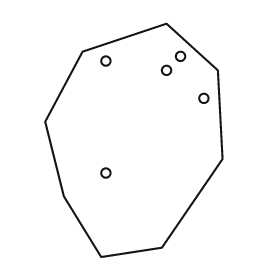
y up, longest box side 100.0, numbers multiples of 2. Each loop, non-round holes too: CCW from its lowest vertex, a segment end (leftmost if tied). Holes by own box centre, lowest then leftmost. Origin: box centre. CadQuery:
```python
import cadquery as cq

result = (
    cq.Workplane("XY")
    .moveTo(-14.0, -50.0)
    .lineTo(12.0, -46.0)
    .lineTo(38.0, -8.0)
    .lineTo(36.0, 30.0)
    .lineTo(14.0, 50.0)
    .lineTo(-22.0, 38.0)
    .lineTo(-38.0, 8.0)
    .lineTo(-30.0, -24.0)
    .close()
    .moveTo(-12.0, -14.0)
    .circle(2.0)
    .moveTo(30.0, 18.0)
    .circle(2.0)
    .moveTo(14.0, 30.0)
    .circle(2.0)
    .moveTo(-12.0, 34.0)
    .circle(2.0)
    .moveTo(20.0, 36.0)
    .circle(2.0)
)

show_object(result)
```